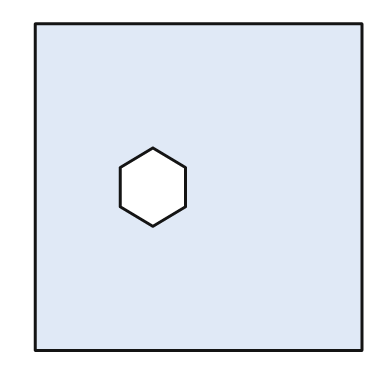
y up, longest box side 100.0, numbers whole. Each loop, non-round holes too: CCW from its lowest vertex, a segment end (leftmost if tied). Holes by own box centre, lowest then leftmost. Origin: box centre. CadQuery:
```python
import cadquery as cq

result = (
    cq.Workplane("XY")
    .moveTo(-50.0, -50.0)
    .lineTo(50.0, -50.0)
    .lineTo(50.0, 50.0)
    .lineTo(-50.0, 50.0)
    .close()
    .moveTo(-14.0, -12.0)
    .lineTo(-4.0, -6.0)
    .lineTo(-4.0, 6.0)
    .lineTo(-14.0, 12.0)
    .lineTo(-24.0, 6.0)
    .lineTo(-24.0, -6.0)
    .close()
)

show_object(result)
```